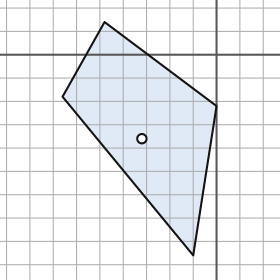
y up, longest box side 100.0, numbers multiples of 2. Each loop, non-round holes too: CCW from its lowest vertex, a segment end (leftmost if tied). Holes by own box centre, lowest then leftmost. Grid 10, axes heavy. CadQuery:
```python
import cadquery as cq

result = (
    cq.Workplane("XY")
    .moveTo(-10.0, -86.0)
    .lineTo(0.0, -22.0)
    .lineTo(-48.0, 14.0)
    .lineTo(-66.0, -18.0)
    .close()
    .moveTo(-32.0, -36.0)
    .circle(2.0)
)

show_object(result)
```